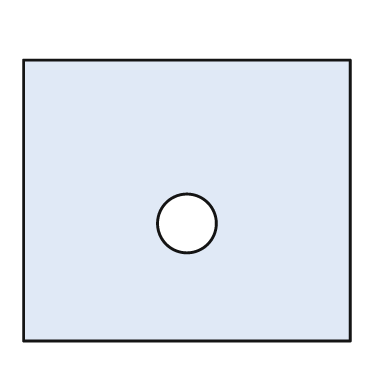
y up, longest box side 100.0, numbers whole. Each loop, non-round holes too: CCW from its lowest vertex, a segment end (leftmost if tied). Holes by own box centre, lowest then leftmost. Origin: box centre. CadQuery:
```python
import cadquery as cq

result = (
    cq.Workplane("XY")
    .moveTo(-50.0, -43.0)
    .lineTo(50.0, -43.0)
    .lineTo(50.0, 43.0)
    .lineTo(-50.0, 43.0)
    .close()
    .moveTo(0.0, -7.0)
    .circle(9.0)
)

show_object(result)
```